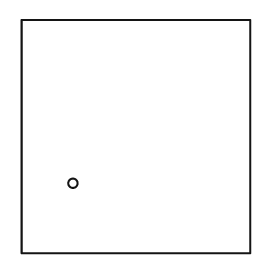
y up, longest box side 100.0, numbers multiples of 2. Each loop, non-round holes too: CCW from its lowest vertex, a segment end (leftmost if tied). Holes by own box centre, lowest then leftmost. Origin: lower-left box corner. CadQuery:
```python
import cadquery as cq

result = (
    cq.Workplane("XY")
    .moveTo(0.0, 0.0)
    .lineTo(98.0, 0.0)
    .lineTo(98.0, 100.0)
    .lineTo(0.0, 100.0)
    .close()
    .moveTo(22.0, 30.0)
    .circle(2.0)
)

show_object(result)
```